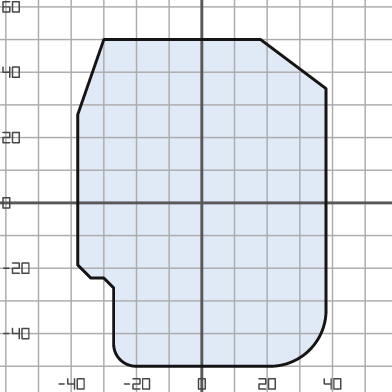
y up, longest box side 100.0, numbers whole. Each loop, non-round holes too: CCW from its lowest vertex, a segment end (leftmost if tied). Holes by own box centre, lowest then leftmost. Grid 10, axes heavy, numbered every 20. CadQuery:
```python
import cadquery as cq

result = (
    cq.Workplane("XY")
    .moveTo(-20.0, -50.0)
    .lineTo(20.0, -50.0)
    .threePointArc((33.0, -45.0), (38.0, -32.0))
    .lineTo(38.0, 35.0)
    .lineTo(18.0, 50.0)
    .lineTo(-30.0, 50.0)
    .lineTo(-38.0, 27.0)
    .lineTo(-38.0, -19.0)
    .lineTo(-34.0, -23.0)
    .lineTo(-30.0, -23.0)
    .lineTo(-27.0, -26.0)
    .lineTo(-27.0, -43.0)
    .threePointArc((-25.0, -48.0), (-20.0, -50.0))
    .close()
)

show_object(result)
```